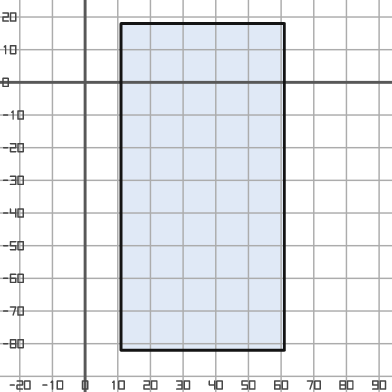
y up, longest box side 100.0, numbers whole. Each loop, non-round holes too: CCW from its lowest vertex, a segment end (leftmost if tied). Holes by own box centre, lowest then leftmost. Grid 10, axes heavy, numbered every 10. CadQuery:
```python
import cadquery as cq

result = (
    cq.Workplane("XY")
    .moveTo(11.0, -82.0)
    .lineTo(61.0, -82.0)
    .lineTo(61.0, 18.0)
    .lineTo(11.0, 18.0)
    .close()
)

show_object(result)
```